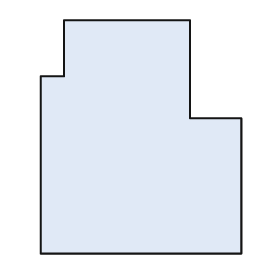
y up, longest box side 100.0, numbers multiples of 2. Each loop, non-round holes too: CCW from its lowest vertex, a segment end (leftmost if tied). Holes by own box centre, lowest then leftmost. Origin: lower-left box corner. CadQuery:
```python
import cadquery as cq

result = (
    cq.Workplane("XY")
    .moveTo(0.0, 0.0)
    .lineTo(86.0, 0.0)
    .lineTo(86.0, 58.0)
    .lineTo(64.0, 58.0)
    .lineTo(64.0, 100.0)
    .lineTo(10.0, 100.0)
    .lineTo(10.0, 76.0)
    .lineTo(0.0, 76.0)
    .close()
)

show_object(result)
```